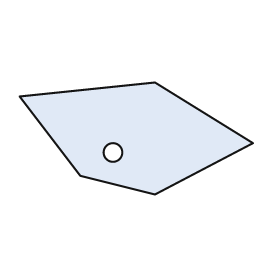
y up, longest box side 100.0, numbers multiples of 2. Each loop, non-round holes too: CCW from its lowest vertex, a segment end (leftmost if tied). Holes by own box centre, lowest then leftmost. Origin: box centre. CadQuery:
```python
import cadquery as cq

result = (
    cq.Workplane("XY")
    .moveTo(8.0, -24.0)
    .lineTo(50.0, -2.0)
    .lineTo(8.0, 24.0)
    .lineTo(-50.0, 18.0)
    .lineTo(-24.0, -16.0)
    .close()
    .moveTo(-10.0, -6.0)
    .circle(4.0)
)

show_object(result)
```